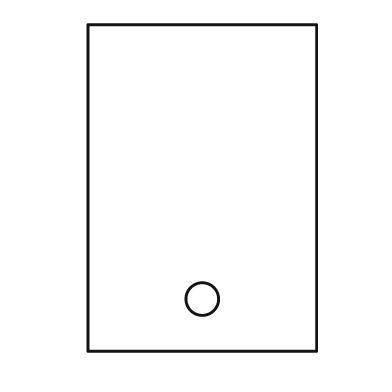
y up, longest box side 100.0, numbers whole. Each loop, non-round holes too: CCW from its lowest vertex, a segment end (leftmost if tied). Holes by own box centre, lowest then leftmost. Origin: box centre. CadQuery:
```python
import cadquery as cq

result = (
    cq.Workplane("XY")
    .moveTo(-35.0, -50.0)
    .lineTo(35.0, -50.0)
    .lineTo(35.0, 50.0)
    .lineTo(-35.0, 50.0)
    .close()
    .moveTo(0.0, -34.0)
    .circle(5.0)
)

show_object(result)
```